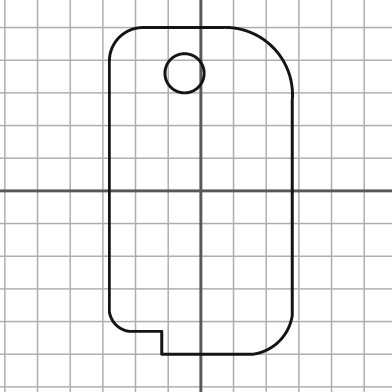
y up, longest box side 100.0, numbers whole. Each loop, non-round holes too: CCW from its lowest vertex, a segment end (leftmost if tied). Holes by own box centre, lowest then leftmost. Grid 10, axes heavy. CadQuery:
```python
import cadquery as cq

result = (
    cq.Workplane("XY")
    .moveTo(-12.0, -50.0)
    .lineTo(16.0, -50.0)
    .threePointArc((24.0, -46.0), (28.0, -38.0))
    .lineTo(28.0, 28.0)
    .threePointArc((22.0, 44.0), (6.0, 50.0))
    .lineTo(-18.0, 50.0)
    .threePointArc((-25.0, 47.0), (-28.0, 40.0))
    .lineTo(-28.0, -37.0)
    .threePointArc((-26.0, -41.0), (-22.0, -43.0))
    .lineTo(-12.0, -43.0)
    .close()
    .moveTo(-5.0, 36.0)
    .circle(6.0)
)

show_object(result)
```